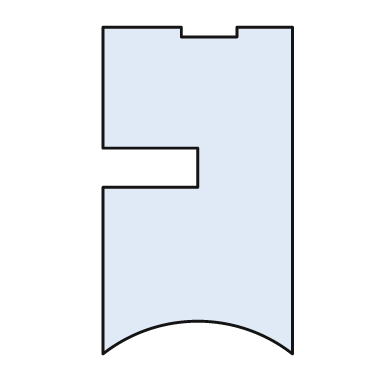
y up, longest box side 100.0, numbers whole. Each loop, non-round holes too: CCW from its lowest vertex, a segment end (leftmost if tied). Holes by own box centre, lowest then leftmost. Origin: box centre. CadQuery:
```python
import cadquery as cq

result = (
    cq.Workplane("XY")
    .moveTo(-29.0, -50.0)
    .threePointArc((0.0, -40.0), (29.0, -50.0))
    .lineTo(29.0, 50.0)
    .lineTo(12.0, 50.0)
    .lineTo(12.0, 47.0)
    .lineTo(-5.0, 47.0)
    .lineTo(-5.0, 50.0)
    .lineTo(-29.0, 50.0)
    .lineTo(-29.0, 13.0)
    .lineTo(0.0, 13.0)
    .lineTo(0.0, 1.0)
    .lineTo(-29.0, 1.0)
    .close()
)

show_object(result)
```